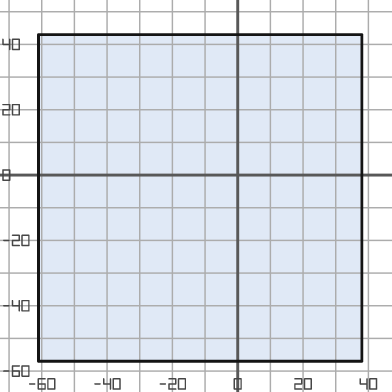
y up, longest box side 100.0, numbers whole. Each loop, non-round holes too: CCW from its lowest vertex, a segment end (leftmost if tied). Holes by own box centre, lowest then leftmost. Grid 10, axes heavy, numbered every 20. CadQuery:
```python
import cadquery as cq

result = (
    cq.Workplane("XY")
    .moveTo(-61.0, -57.0)
    .lineTo(38.0, -57.0)
    .lineTo(38.0, 43.0)
    .lineTo(-61.0, 43.0)
    .close()
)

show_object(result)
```